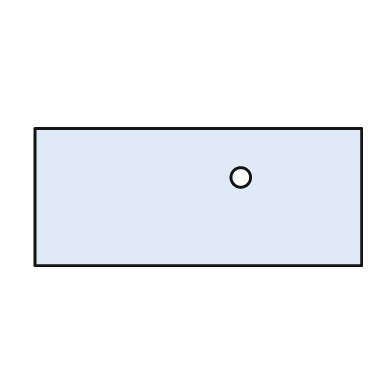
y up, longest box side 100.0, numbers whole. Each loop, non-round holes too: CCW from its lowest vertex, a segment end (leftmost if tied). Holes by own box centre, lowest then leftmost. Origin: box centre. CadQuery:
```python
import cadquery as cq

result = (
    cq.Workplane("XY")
    .moveTo(-50.0, -21.0)
    .lineTo(50.0, -21.0)
    .lineTo(50.0, 21.0)
    .lineTo(-50.0, 21.0)
    .close()
    .moveTo(13.0, 6.0)
    .circle(3.0)
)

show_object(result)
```